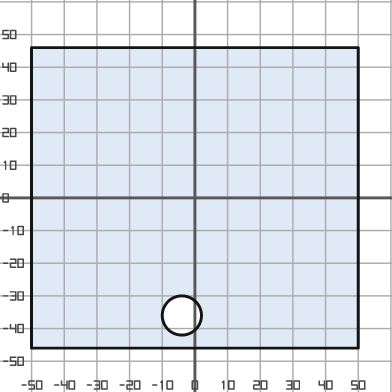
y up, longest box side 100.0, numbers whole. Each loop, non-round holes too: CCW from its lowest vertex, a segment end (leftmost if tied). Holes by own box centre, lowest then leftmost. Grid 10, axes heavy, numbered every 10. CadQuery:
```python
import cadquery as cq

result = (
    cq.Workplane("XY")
    .moveTo(-50.0, -46.0)
    .lineTo(50.0, -46.0)
    .lineTo(50.0, 46.0)
    .lineTo(-50.0, 46.0)
    .close()
    .moveTo(-4.0, -36.0)
    .circle(6.0)
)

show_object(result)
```